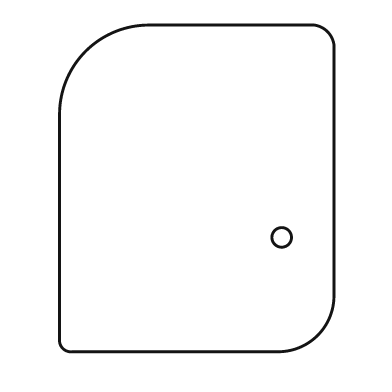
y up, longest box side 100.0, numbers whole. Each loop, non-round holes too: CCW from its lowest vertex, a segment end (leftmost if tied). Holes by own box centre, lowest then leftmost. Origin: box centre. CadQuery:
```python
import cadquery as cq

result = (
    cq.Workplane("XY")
    .moveTo(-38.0, -50.0)
    .lineTo(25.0, -50.0)
    .threePointArc((37.0, -45.0), (42.0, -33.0))
    .lineTo(42.0, 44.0)
    .threePointArc((40.0, 48.0), (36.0, 50.0))
    .lineTo(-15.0, 50.0)
    .threePointArc((-34.0, 42.0), (-42.0, 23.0))
    .lineTo(-42.0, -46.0)
    .threePointArc((-41.0, -49.0), (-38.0, -50.0))
    .close()
    .moveTo(26.0, -15.0)
    .circle(3.0)
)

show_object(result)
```